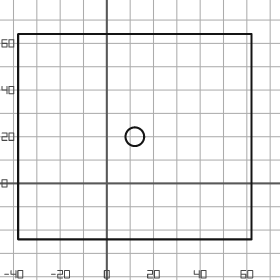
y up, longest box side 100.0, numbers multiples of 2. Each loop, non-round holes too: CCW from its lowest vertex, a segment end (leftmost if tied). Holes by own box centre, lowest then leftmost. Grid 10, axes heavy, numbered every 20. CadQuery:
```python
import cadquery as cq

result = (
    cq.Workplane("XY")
    .moveTo(-38.0, -24.0)
    .lineTo(62.0, -24.0)
    .lineTo(62.0, 64.0)
    .lineTo(-38.0, 64.0)
    .close()
    .moveTo(12.0, 20.0)
    .circle(4.0)
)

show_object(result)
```